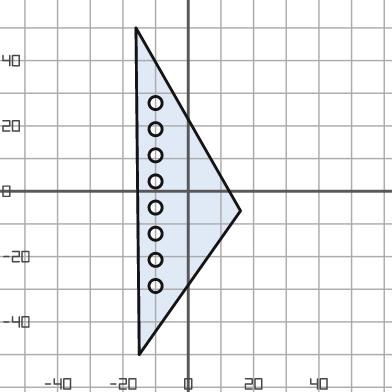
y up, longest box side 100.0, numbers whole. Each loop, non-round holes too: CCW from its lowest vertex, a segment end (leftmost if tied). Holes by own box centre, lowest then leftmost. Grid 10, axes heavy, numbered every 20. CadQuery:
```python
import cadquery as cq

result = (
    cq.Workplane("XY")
    .moveTo(-15.0, -50.0)
    .lineTo(16.0, -6.0)
    .lineTo(-16.0, 50.0)
    .close()
    .moveTo(-10.0, -29.0)
    .circle(2.0)
    .moveTo(-10.0, -21.0)
    .circle(2.0)
    .moveTo(-10.0, -13.0)
    .circle(2.0)
    .moveTo(-10.0, -5.0)
    .circle(2.0)
    .moveTo(-10.0, 3.0)
    .circle(2.0)
    .moveTo(-10.0, 11.0)
    .circle(2.0)
    .moveTo(-10.0, 19.0)
    .circle(2.0)
    .moveTo(-10.0, 27.0)
    .circle(2.0)
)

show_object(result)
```